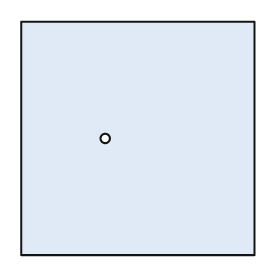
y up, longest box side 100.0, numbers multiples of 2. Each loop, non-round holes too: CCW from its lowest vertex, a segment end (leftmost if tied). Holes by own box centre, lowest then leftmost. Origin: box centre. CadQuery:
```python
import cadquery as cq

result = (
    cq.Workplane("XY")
    .moveTo(-50.0, -50.0)
    .lineTo(50.0, -50.0)
    .lineTo(50.0, 50.0)
    .lineTo(-50.0, 50.0)
    .close()
    .moveTo(-14.0, 0.0)
    .circle(2.0)
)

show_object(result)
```